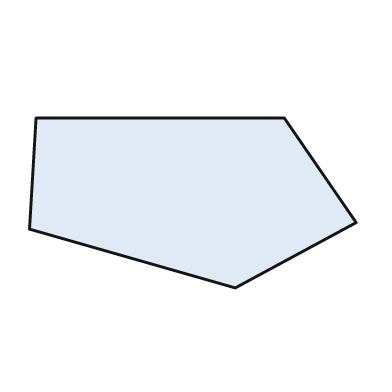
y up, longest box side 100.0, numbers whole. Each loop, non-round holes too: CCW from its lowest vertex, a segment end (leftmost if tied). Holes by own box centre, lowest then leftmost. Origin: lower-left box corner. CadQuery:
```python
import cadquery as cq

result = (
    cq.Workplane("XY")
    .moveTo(63.0, 0.0)
    .lineTo(100.0, 20.0)
    .lineTo(78.0, 52.0)
    .lineTo(2.0, 52.0)
    .lineTo(0.0, 18.0)
    .close()
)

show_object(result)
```